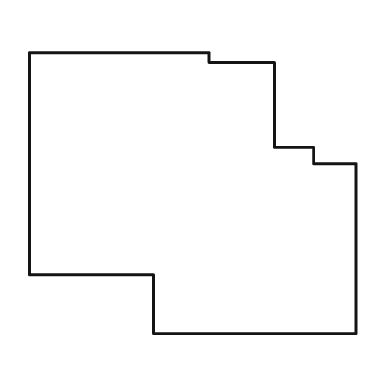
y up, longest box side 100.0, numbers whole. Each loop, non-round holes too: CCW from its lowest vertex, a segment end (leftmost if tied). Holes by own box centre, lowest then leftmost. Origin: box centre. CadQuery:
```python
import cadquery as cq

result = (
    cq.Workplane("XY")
    .moveTo(-12.0, -43.0)
    .lineTo(50.0, -43.0)
    .lineTo(50.0, 9.0)
    .lineTo(37.0, 9.0)
    .lineTo(37.0, 14.0)
    .lineTo(25.0, 14.0)
    .lineTo(25.0, 40.0)
    .lineTo(5.0, 40.0)
    .lineTo(5.0, 43.0)
    .lineTo(-50.0, 43.0)
    .lineTo(-50.0, -25.0)
    .lineTo(-12.0, -25.0)
    .close()
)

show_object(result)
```